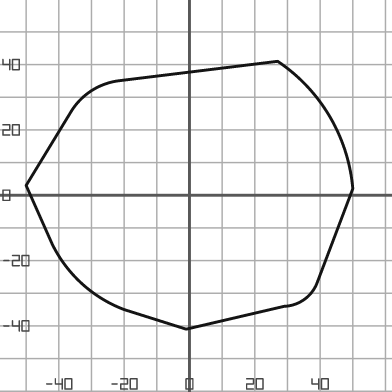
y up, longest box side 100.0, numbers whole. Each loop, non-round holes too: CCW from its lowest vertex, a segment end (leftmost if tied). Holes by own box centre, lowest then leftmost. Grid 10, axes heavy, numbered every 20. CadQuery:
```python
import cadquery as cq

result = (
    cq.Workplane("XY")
    .moveTo(-1.0, -41.0)
    .lineTo(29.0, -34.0)
    .threePointArc((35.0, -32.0), (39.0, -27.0))
    .lineTo(50.0, 2.0)
    .threePointArc((43.0, 24.0), (27.0, 41.0))
    .lineTo(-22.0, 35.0)
    .threePointArc((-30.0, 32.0), (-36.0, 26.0))
    .lineTo(-50.0, 3.0)
    .lineTo(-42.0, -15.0)
    .threePointArc((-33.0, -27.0), (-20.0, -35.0))
    .close()
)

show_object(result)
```